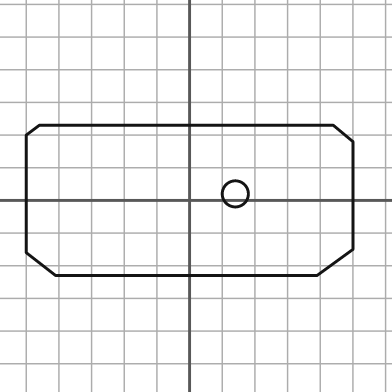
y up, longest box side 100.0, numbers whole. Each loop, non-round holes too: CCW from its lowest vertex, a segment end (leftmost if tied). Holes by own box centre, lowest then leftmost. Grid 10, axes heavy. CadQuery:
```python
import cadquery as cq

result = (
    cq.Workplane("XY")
    .moveTo(-41.0, -23.0)
    .lineTo(39.0, -23.0)
    .lineTo(50.0, -15.0)
    .lineTo(50.0, 18.0)
    .lineTo(44.0, 23.0)
    .lineTo(-46.0, 23.0)
    .lineTo(-50.0, 20.0)
    .lineTo(-50.0, -16.0)
    .close()
    .moveTo(14.0, 2.0)
    .circle(4.0)
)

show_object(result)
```